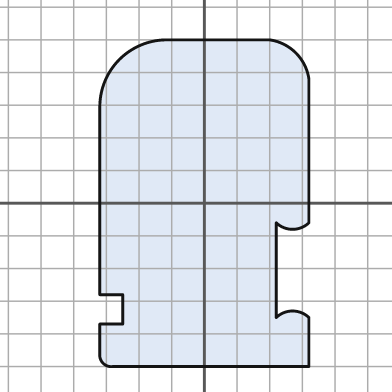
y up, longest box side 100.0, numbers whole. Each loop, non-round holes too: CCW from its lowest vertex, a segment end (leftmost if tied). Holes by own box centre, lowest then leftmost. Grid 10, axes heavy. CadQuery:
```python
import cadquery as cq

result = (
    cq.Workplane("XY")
    .moveTo(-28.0, -50.0)
    .lineTo(32.0, -50.0)
    .lineTo(32.0, -35.0)
    .threePointArc((27.0, -33.0), (22.0, -35.0))
    .lineTo(22.0, -6.0)
    .threePointArc((27.0, -8.0), (32.0, -6.0))
    .lineTo(32.0, 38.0)
    .threePointArc((28.0, 46.0), (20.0, 50.0))
    .lineTo(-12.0, 50.0)
    .threePointArc((-26.0, 44.0), (-32.0, 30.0))
    .lineTo(-32.0, -28.0)
    .lineTo(-25.0, -28.0)
    .lineTo(-25.0, -37.0)
    .lineTo(-32.0, -37.0)
    .lineTo(-32.0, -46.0)
    .threePointArc((-31.0, -49.0), (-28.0, -50.0))
    .close()
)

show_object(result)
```